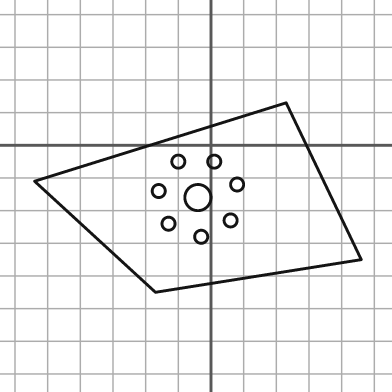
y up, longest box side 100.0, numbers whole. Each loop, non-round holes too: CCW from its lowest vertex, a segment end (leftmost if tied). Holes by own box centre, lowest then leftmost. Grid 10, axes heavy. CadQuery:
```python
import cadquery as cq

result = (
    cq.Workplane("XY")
    .moveTo(-17.0, -45.0)
    .lineTo(46.0, -35.0)
    .lineTo(23.0, 13.0)
    .lineTo(-54.0, -11.0)
    .close()
    .moveTo(-3.0, -28.0)
    .circle(2.0)
    .moveTo(-13.0, -24.0)
    .circle(2.0)
    .moveTo(6.0, -23.0)
    .circle(2.0)
    .moveTo(-4.0, -16.0)
    .circle(4.0)
    .moveTo(-16.0, -14.0)
    .circle(2.0)
    .moveTo(8.0, -12.0)
    .circle(2.0)
    .moveTo(-10.0, -5.0)
    .circle(2.0)
    .moveTo(1.0, -5.0)
    .circle(2.0)
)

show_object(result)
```